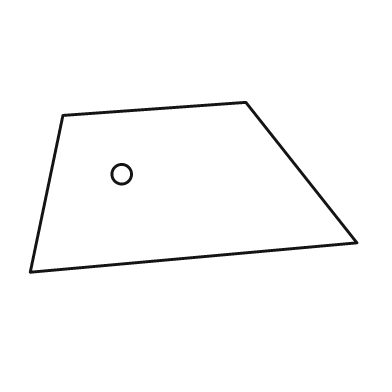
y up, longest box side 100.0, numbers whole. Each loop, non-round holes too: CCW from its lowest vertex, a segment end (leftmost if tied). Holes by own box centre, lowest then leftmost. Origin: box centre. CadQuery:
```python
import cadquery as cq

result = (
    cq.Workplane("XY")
    .moveTo(-50.0, -26.0)
    .lineTo(50.0, -17.0)
    .lineTo(16.0, 26.0)
    .lineTo(-40.0, 22.0)
    .close()
    .moveTo(-22.0, 4.0)
    .circle(3.0)
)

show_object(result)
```